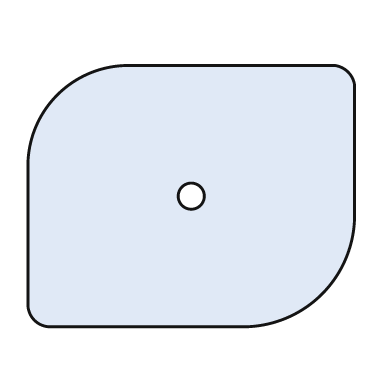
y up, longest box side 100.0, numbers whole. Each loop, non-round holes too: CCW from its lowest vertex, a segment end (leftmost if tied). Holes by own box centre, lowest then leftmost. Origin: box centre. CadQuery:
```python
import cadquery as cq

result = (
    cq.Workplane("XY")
    .moveTo(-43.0, -40.0)
    .lineTo(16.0, -40.0)
    .threePointArc((40.0, -30.0), (50.0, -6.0))
    .lineTo(50.0, 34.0)
    .threePointArc((48.0, 38.0), (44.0, 40.0))
    .lineTo(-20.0, 40.0)
    .threePointArc((-41.0, 31.0), (-50.0, 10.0))
    .lineTo(-50.0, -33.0)
    .threePointArc((-48.0, -38.0), (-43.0, -40.0))
    .close()
    .moveTo(0.0, 0.0)
    .circle(4.0)
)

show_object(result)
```